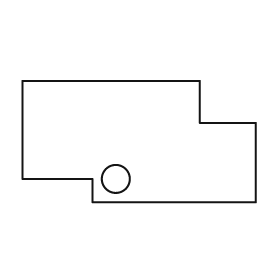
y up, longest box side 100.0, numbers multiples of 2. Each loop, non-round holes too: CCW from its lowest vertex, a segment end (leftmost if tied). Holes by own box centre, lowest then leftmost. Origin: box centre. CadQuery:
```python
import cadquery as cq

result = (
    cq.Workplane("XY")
    .moveTo(-20.0, -26.0)
    .lineTo(50.0, -26.0)
    .lineTo(50.0, 8.0)
    .lineTo(26.0, 8.0)
    .lineTo(26.0, 26.0)
    .lineTo(-50.0, 26.0)
    .lineTo(-50.0, -16.0)
    .lineTo(-20.0, -16.0)
    .close()
    .moveTo(-10.0, -16.0)
    .circle(6.0)
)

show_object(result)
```